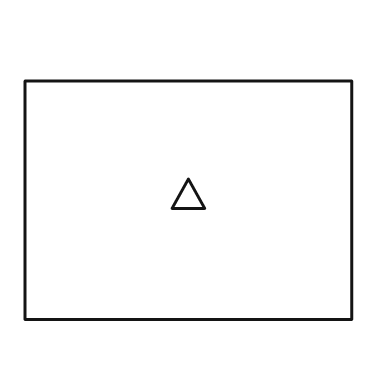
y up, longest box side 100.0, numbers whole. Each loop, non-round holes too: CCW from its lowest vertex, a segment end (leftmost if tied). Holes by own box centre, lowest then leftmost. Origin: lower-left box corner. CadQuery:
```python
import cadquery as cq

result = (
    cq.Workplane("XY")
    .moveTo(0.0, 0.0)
    .lineTo(100.0, 0.0)
    .lineTo(100.0, 73.0)
    .lineTo(0.0, 73.0)
    .close()
    .moveTo(45.0, 34.0)
    .lineTo(55.0, 34.0)
    .lineTo(50.0, 43.0)
    .close()
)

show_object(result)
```